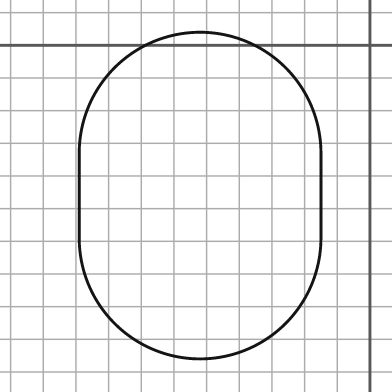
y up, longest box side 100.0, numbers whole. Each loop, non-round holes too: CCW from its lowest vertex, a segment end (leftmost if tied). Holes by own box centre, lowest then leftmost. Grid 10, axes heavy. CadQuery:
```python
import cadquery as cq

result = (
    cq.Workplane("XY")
    .moveTo(-89.0, -59.0)
    .threePointArc((-52.0, -96.0), (-15.0, -59.0))
    .lineTo(-15.0, -33.0)
    .threePointArc((-52.0, 4.0), (-89.0, -33.0))
    .close()
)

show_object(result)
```